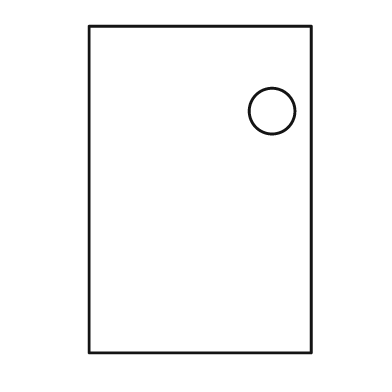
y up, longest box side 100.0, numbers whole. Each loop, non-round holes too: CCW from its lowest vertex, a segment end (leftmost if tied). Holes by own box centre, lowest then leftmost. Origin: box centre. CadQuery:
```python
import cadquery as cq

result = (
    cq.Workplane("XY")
    .moveTo(-34.0, -50.0)
    .lineTo(34.0, -50.0)
    .lineTo(34.0, 50.0)
    .lineTo(-34.0, 50.0)
    .close()
    .moveTo(22.0, 24.0)
    .circle(7.0)
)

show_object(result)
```